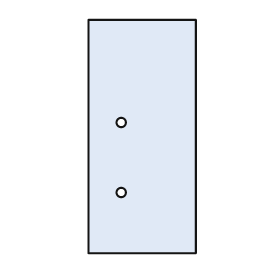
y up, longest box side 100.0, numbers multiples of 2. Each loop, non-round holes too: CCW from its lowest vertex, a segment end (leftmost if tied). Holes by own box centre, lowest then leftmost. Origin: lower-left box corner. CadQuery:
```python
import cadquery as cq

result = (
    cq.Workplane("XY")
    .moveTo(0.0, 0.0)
    .lineTo(46.0, 0.0)
    .lineTo(46.0, 100.0)
    .lineTo(0.0, 100.0)
    .close()
    .moveTo(14.0, 26.0)
    .circle(2.0)
    .moveTo(14.0, 56.0)
    .circle(2.0)
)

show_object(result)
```